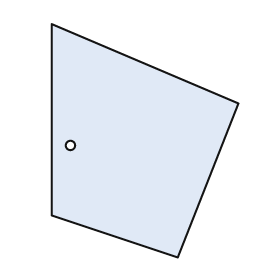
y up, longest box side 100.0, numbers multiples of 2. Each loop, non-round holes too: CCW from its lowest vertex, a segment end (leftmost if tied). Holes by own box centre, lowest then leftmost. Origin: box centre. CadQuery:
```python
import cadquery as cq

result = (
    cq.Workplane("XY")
    .moveTo(14.0, -50.0)
    .lineTo(40.0, 16.0)
    .lineTo(-40.0, 50.0)
    .lineTo(-40.0, -32.0)
    .close()
    .moveTo(-32.0, -2.0)
    .circle(2.0)
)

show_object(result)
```